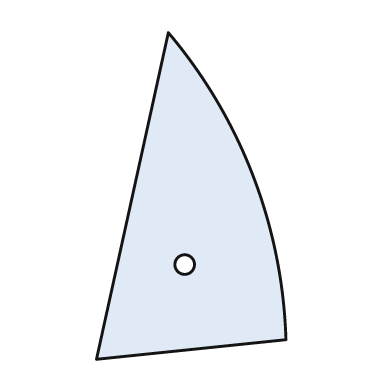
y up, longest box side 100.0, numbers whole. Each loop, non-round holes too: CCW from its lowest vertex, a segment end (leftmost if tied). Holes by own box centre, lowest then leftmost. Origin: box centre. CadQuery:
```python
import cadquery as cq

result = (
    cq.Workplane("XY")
    .moveTo(-29.0, -50.0)
    .lineTo(29.0, -44.0)
    .threePointArc((19.0, 6.0), (-7.0, 50.0))
    .close()
    .moveTo(-2.0, -21.0)
    .circle(3.0)
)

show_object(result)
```